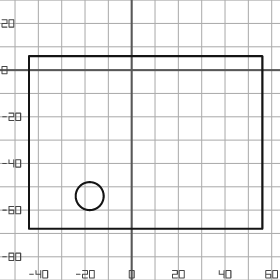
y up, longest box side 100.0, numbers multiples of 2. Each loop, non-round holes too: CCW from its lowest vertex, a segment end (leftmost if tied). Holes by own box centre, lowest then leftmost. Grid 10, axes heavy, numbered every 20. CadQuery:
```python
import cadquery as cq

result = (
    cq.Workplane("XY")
    .moveTo(-44.0, -68.0)
    .lineTo(56.0, -68.0)
    .lineTo(56.0, 6.0)
    .lineTo(-44.0, 6.0)
    .close()
    .moveTo(-18.0, -54.0)
    .circle(6.0)
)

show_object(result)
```